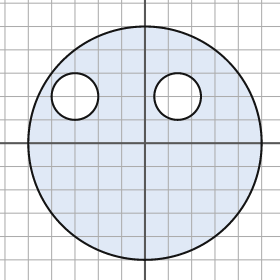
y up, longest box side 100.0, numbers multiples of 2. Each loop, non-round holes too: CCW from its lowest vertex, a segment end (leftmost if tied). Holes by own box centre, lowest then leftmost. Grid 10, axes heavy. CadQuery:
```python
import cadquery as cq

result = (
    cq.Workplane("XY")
    .moveTo(0.0, 0.0)
    .circle(50.0)
    .moveTo(-30.0, 20.0)
    .circle(10.0)
    .moveTo(14.0, 20.0)
    .circle(10.0)
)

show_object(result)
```